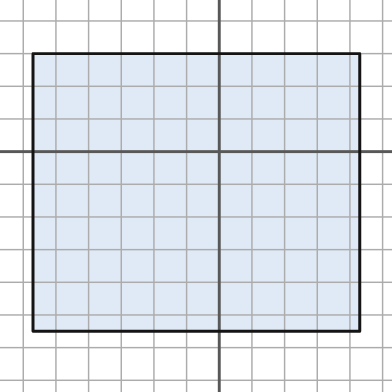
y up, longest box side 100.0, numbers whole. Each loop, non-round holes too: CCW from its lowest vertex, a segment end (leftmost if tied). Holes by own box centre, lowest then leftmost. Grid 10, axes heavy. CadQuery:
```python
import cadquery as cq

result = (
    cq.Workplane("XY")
    .moveTo(-57.0, -55.0)
    .lineTo(43.0, -55.0)
    .lineTo(43.0, 30.0)
    .lineTo(-57.0, 30.0)
    .close()
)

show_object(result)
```